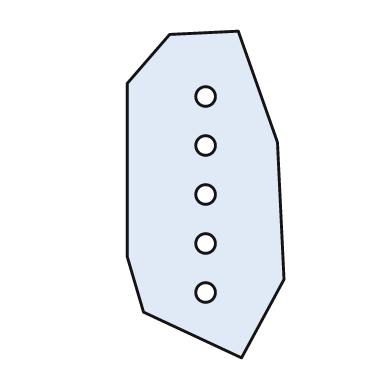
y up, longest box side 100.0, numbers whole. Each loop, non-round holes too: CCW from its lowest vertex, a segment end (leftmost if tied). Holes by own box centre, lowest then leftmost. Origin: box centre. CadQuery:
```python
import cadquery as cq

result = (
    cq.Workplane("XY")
    .moveTo(11.0, -50.0)
    .lineTo(24.0, -26.0)
    .lineTo(22.0, 16.0)
    .lineTo(10.0, 50.0)
    .lineTo(-11.0, 49.0)
    .lineTo(-24.0, 34.0)
    .lineTo(-24.0, -19.0)
    .lineTo(-19.0, -36.0)
    .close()
    .moveTo(0.0, -30.0)
    .circle(3.0)
    .moveTo(0.0, -15.0)
    .circle(3.0)
    .moveTo(0.0, 0.0)
    .circle(3.0)
    .moveTo(0.0, 15.0)
    .circle(3.0)
    .moveTo(0.0, 30.0)
    .circle(3.0)
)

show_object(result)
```